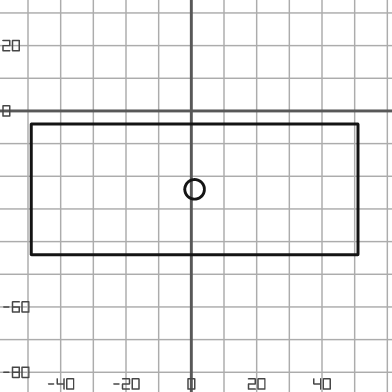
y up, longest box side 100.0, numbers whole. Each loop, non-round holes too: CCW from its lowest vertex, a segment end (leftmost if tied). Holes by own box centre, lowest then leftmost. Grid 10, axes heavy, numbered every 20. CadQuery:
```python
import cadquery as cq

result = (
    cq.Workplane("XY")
    .moveTo(-49.0, -44.0)
    .lineTo(51.0, -44.0)
    .lineTo(51.0, -4.0)
    .lineTo(-49.0, -4.0)
    .close()
    .moveTo(1.0, -24.0)
    .circle(3.0)
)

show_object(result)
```